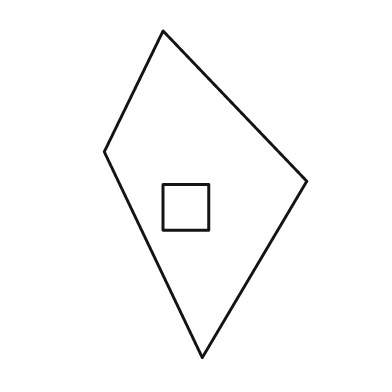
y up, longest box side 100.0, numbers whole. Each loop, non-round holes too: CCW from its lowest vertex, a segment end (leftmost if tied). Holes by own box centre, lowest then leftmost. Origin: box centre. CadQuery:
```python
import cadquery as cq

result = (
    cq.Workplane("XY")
    .moveTo(-1.0, -50.0)
    .lineTo(31.0, 4.0)
    .lineTo(-13.0, 50.0)
    .lineTo(-31.0, 13.0)
    .close()
    .moveTo(-13.0, -11.0)
    .lineTo(1.0, -11.0)
    .lineTo(1.0, 3.0)
    .lineTo(-13.0, 3.0)
    .close()
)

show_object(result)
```